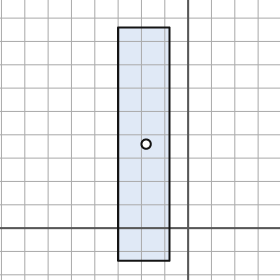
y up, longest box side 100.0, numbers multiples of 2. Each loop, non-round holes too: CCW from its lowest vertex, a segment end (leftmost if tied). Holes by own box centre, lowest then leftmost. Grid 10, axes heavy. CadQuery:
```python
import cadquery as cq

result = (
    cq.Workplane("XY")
    .moveTo(-30.0, -14.0)
    .lineTo(-8.0, -14.0)
    .lineTo(-8.0, 86.0)
    .lineTo(-30.0, 86.0)
    .close()
    .moveTo(-18.0, 36.0)
    .circle(2.0)
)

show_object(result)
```